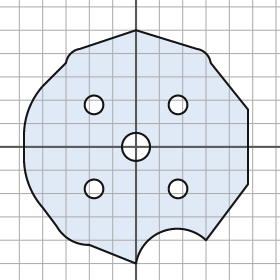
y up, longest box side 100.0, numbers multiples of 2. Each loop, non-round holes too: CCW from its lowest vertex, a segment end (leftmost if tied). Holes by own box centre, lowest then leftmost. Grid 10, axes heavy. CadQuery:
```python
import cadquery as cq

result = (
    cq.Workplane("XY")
    .moveTo(0.0, -50.0)
    .threePointArc((12.0, -36.0), (30.0, -40.0))
    .lineTo(48.0, -16.0)
    .lineTo(48.0, 16.0)
    .lineTo(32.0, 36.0)
    .threePointArc((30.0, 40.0), (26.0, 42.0))
    .lineTo(0.0, 50.0)
    .lineTo(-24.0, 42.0)
    .threePointArc((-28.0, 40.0), (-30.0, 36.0))
    .lineTo(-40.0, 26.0)
    .threePointArc((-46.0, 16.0), (-48.0, 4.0))
    .lineTo(-48.0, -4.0)
    .threePointArc((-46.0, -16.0), (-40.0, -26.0))
    .lineTo(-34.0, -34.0)
    .threePointArc((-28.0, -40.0), (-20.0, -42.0))
    .close()
    .moveTo(-18.0, -18.0)
    .circle(4.0)
    .moveTo(18.0, -18.0)
    .circle(4.0)
    .moveTo(0.0, 0.0)
    .circle(6.0)
    .moveTo(-18.0, 18.0)
    .circle(4.0)
    .moveTo(18.0, 18.0)
    .circle(4.0)
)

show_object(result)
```